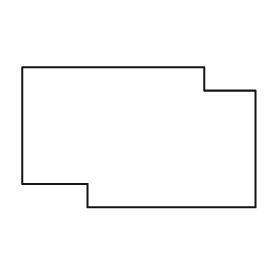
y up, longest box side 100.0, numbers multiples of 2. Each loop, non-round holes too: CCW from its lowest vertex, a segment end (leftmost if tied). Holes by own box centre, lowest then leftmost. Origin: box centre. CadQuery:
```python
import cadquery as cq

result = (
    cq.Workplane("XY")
    .moveTo(-22.0, -30.0)
    .lineTo(50.0, -30.0)
    .lineTo(50.0, 20.0)
    .lineTo(28.0, 20.0)
    .lineTo(28.0, 30.0)
    .lineTo(-50.0, 30.0)
    .lineTo(-50.0, -20.0)
    .lineTo(-22.0, -20.0)
    .close()
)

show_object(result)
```